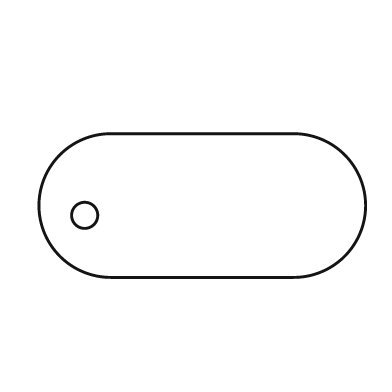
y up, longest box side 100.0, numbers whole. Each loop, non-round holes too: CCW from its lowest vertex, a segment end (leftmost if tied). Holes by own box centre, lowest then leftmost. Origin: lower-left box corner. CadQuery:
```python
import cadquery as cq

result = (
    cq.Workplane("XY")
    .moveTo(22.0, 0.0)
    .lineTo(78.0, 0.0)
    .threePointArc((100.0, 22.0), (78.0, 44.0))
    .lineTo(22.0, 44.0)
    .threePointArc((0.0, 22.0), (22.0, 0.0))
    .close()
    .moveTo(14.0, 19.0)
    .circle(4.0)
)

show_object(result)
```